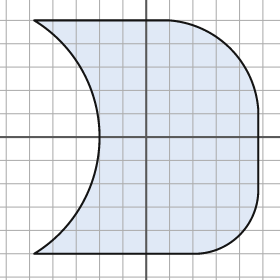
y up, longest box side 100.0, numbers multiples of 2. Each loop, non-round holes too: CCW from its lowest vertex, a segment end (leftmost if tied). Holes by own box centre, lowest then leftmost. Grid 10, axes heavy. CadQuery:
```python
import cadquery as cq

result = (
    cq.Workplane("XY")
    .moveTo(-48.0, -50.0)
    .lineTo(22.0, -50.0)
    .threePointArc((40.0, -42.0), (48.0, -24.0))
    .lineTo(48.0, 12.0)
    .threePointArc((36.0, 38.0), (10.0, 50.0))
    .lineTo(-48.0, 50.0)
    .threePointArc((-20.0, 0.0), (-48.0, -50.0))
    .close()
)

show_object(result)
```